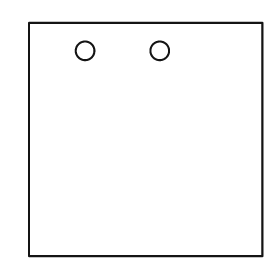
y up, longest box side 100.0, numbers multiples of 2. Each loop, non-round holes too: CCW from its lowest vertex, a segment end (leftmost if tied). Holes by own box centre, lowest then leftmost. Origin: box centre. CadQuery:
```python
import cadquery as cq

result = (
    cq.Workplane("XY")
    .moveTo(-50.0, -50.0)
    .lineTo(50.0, -50.0)
    .lineTo(50.0, 50.0)
    .lineTo(-50.0, 50.0)
    .close()
    .moveTo(-26.0, 38.0)
    .circle(4.0)
    .moveTo(6.0, 38.0)
    .circle(4.0)
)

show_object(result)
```